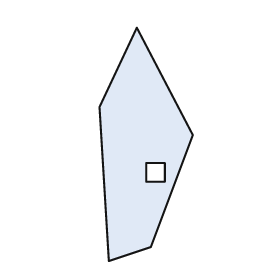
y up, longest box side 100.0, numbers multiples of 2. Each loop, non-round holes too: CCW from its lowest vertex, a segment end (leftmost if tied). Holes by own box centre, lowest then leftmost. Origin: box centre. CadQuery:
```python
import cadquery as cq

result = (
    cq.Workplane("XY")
    .moveTo(-16.0, -50.0)
    .lineTo(2.0, -44.0)
    .lineTo(20.0, 4.0)
    .lineTo(-4.0, 50.0)
    .lineTo(-20.0, 16.0)
    .close()
    .moveTo(0.0, -16.0)
    .lineTo(8.0, -16.0)
    .lineTo(8.0, -8.0)
    .lineTo(0.0, -8.0)
    .close()
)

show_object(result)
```